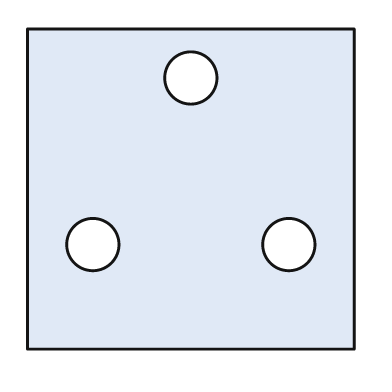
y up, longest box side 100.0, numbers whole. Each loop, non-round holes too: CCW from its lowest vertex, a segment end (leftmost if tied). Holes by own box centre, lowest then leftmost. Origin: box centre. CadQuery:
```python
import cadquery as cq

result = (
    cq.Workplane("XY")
    .moveTo(-50.0, -49.0)
    .lineTo(50.0, -49.0)
    .lineTo(50.0, 49.0)
    .lineTo(-50.0, 49.0)
    .close()
    .moveTo(-30.0, -17.0)
    .circle(8.0)
    .moveTo(30.0, -17.0)
    .circle(8.0)
    .moveTo(0.0, 34.0)
    .circle(8.0)
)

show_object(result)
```